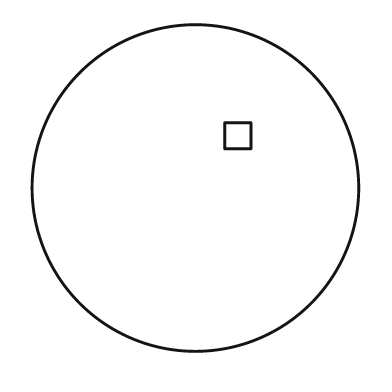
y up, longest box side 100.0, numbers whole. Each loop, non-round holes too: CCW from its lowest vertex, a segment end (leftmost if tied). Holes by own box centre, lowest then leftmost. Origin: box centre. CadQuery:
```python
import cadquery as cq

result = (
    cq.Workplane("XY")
    .moveTo(0.0, 0.0)
    .circle(50.0)
    .moveTo(9.0, 12.0)
    .lineTo(17.0, 12.0)
    .lineTo(17.0, 20.0)
    .lineTo(9.0, 20.0)
    .close()
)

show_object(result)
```